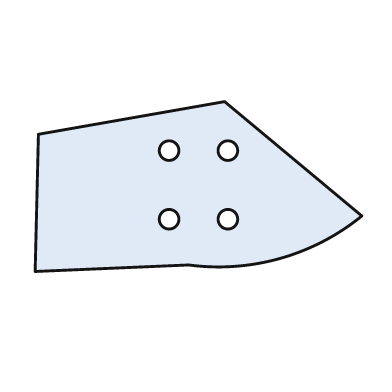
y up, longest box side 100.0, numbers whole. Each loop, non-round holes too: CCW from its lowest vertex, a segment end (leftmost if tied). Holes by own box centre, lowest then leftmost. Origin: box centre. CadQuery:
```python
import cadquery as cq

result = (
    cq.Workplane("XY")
    .moveTo(-50.0, -26.0)
    .lineTo(-3.0, -24.0)
    .threePointArc((25.0, -22.0), (50.0, -9.0))
    .lineTo(8.0, 26.0)
    .lineTo(-49.0, 16.0)
    .close()
    .moveTo(-9.0, -10.0)
    .circle(3.0)
    .moveTo(9.0, -10.0)
    .circle(3.0)
    .moveTo(-9.0, 11.0)
    .circle(3.0)
    .moveTo(9.0, 11.0)
    .circle(3.0)
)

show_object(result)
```